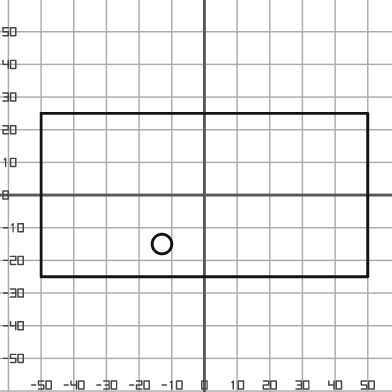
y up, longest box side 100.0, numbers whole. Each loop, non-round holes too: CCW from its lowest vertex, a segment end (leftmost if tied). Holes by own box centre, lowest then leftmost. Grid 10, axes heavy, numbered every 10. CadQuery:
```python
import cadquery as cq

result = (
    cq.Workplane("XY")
    .moveTo(-50.0, -25.0)
    .lineTo(50.0, -25.0)
    .lineTo(50.0, 25.0)
    .lineTo(-50.0, 25.0)
    .close()
    .moveTo(-13.0, -15.0)
    .circle(3.0)
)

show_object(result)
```